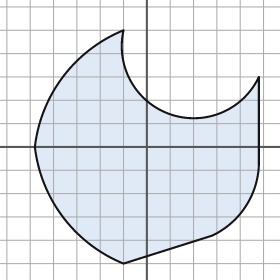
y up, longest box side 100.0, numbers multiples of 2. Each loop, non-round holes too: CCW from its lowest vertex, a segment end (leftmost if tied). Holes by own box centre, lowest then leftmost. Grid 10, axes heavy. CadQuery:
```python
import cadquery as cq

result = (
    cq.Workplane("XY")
    .moveTo(-10.0, -50.0)
    .lineTo(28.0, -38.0)
    .threePointArc((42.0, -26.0), (48.0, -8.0))
    .lineTo(48.0, 30.0)
    .threePointArc((10.0, 14.0), (-10.0, 50.0))
    .threePointArc((-36.0, 30.0), (-48.0, 0.0))
    .threePointArc((-36.0, -30.0), (-10.0, -50.0))
    .close()
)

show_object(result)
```